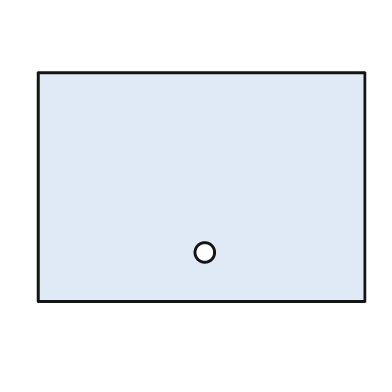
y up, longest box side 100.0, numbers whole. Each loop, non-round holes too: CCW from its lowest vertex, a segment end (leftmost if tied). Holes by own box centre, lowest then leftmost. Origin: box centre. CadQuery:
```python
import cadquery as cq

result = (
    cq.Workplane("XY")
    .moveTo(-50.0, -35.0)
    .lineTo(50.0, -35.0)
    .lineTo(50.0, 35.0)
    .lineTo(-50.0, 35.0)
    .close()
    .moveTo(1.0, -20.0)
    .circle(3.0)
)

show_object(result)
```